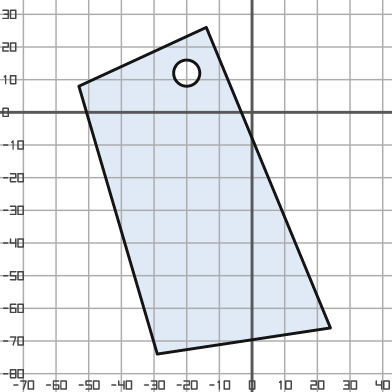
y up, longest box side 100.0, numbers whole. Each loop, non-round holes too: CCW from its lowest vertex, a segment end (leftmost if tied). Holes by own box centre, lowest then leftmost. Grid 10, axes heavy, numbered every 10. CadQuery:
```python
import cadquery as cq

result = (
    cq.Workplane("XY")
    .moveTo(-29.0, -74.0)
    .lineTo(24.0, -66.0)
    .lineTo(-14.0, 26.0)
    .lineTo(-53.0, 8.0)
    .close()
    .moveTo(-20.0, 12.0)
    .circle(4.0)
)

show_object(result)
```